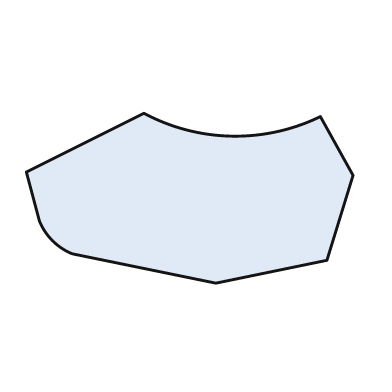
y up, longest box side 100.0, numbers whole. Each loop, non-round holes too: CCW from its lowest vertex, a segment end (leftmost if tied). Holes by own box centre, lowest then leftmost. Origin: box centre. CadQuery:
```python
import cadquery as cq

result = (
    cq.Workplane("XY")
    .moveTo(8.0, -26.0)
    .lineTo(42.0, -19.0)
    .lineTo(50.0, 7.0)
    .lineTo(40.0, 25.0)
    .threePointArc((13.0, 19.0), (-14.0, 26.0))
    .lineTo(-50.0, 8.0)
    .lineTo(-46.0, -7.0)
    .threePointArc((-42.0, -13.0), (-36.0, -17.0))
    .close()
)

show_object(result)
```